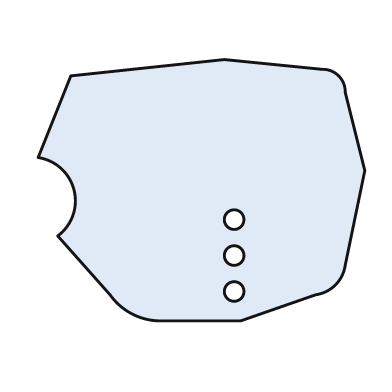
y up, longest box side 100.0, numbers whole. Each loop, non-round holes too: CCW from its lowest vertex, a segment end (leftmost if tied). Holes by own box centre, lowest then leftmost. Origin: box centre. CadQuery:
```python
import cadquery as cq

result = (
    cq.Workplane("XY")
    .moveTo(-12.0, -40.0)
    .lineTo(12.0, -40.0)
    .lineTo(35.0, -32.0)
    .threePointArc((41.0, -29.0), (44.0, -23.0))
    .lineTo(50.0, 6.0)
    .lineTo(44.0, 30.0)
    .threePointArc((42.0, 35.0), (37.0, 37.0))
    .lineTo(7.0, 40.0)
    .lineTo(-40.0, 35.0)
    .lineTo(-50.0, 10.0)
    .threePointArc((-39.0, 0.0), (-44.0, -14.0))
    .lineTo(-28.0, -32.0)
    .threePointArc((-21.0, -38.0), (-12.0, -40.0))
    .close()
    .moveTo(10.0, -31.0)
    .circle(3.0)
    .moveTo(10.0, -20.0)
    .circle(3.0)
    .moveTo(10.0, -9.0)
    .circle(3.0)
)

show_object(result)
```